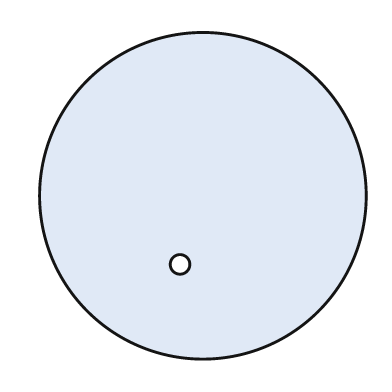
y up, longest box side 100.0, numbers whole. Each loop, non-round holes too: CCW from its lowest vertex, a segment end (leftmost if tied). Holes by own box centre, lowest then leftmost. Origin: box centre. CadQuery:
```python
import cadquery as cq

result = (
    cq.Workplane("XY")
    .moveTo(0.0, 0.0)
    .circle(50.0)
    .moveTo(-7.0, -21.0)
    .circle(3.0)
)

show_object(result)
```